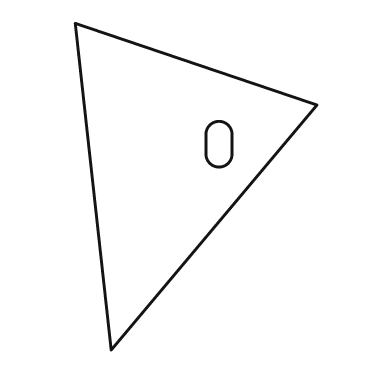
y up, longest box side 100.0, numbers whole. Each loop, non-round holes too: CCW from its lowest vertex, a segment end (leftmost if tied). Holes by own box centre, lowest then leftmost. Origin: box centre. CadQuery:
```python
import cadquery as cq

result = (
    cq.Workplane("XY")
    .moveTo(-26.0, -50.0)
    .lineTo(37.0, 25.0)
    .lineTo(-37.0, 50.0)
    .close()
    .moveTo(3.0, 10.0)
    .threePointArc((7.0, 6.0), (11.0, 10.0))
    .lineTo(11.0, 16.0)
    .threePointArc((7.0, 20.0), (3.0, 16.0))
    .close()
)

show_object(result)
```